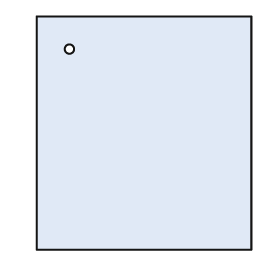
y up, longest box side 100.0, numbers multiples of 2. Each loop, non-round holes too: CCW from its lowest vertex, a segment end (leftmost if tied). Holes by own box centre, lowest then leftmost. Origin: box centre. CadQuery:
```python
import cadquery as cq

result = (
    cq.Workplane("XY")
    .moveTo(-46.0, -50.0)
    .lineTo(46.0, -50.0)
    .lineTo(46.0, 50.0)
    .lineTo(-46.0, 50.0)
    .close()
    .moveTo(-32.0, 36.0)
    .circle(2.0)
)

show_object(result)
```